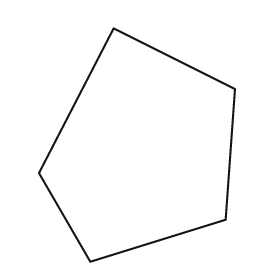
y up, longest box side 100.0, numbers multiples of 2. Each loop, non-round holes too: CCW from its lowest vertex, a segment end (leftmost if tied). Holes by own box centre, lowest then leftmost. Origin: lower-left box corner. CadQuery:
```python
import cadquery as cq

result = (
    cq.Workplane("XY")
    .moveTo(22.0, 0.0)
    .lineTo(80.0, 18.0)
    .lineTo(84.0, 74.0)
    .lineTo(32.0, 100.0)
    .lineTo(0.0, 38.0)
    .close()
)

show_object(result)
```